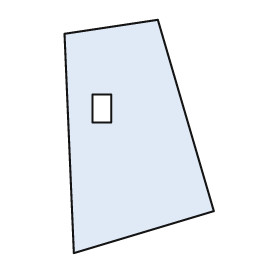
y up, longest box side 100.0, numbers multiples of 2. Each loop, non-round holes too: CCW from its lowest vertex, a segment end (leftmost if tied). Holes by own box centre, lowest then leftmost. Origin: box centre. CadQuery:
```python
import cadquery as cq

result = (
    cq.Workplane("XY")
    .moveTo(-28.0, -50.0)
    .lineTo(32.0, -32.0)
    .lineTo(8.0, 50.0)
    .lineTo(-32.0, 44.0)
    .close()
    .moveTo(-20.0, 6.0)
    .lineTo(-12.0, 6.0)
    .lineTo(-12.0, 18.0)
    .lineTo(-20.0, 18.0)
    .close()
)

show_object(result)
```